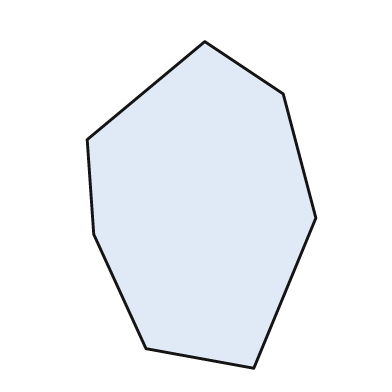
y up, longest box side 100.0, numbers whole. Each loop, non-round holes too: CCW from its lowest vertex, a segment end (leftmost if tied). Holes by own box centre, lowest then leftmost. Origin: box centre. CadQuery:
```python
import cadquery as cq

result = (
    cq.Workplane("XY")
    .moveTo(16.0, -50.0)
    .lineTo(35.0, -4.0)
    .lineTo(25.0, 34.0)
    .lineTo(1.0, 50.0)
    .lineTo(-35.0, 20.0)
    .lineTo(-33.0, -9.0)
    .lineTo(-17.0, -44.0)
    .close()
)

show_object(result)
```